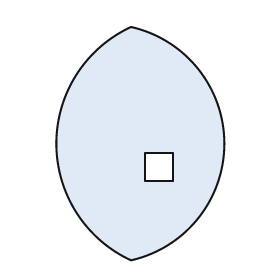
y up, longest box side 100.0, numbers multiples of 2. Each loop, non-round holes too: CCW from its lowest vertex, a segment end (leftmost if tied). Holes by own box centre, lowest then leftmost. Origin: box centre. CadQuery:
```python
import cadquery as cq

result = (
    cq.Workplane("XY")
    .moveTo(-4.0, -50.0)
    .threePointArc((36.0, 0.0), (-4.0, 50.0))
    .threePointArc((-36.0, 0.0), (-4.0, -50.0))
    .close()
    .moveTo(2.0, -16.0)
    .lineTo(14.0, -16.0)
    .lineTo(14.0, -4.0)
    .lineTo(2.0, -4.0)
    .close()
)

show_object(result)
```